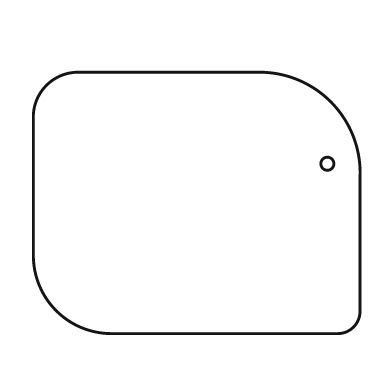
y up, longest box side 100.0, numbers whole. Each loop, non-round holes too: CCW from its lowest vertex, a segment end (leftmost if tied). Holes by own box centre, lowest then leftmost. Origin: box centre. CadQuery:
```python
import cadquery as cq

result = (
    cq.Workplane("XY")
    .moveTo(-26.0, -40.0)
    .lineTo(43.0, -40.0)
    .threePointArc((48.0, -38.0), (50.0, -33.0))
    .lineTo(50.0, 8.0)
    .threePointArc((41.0, 31.0), (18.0, 40.0))
    .lineTo(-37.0, 40.0)
    .threePointArc((-46.0, 36.0), (-50.0, 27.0))
    .lineTo(-50.0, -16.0)
    .threePointArc((-43.0, -33.0), (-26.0, -40.0))
    .close()
    .moveTo(40.0, 12.0)
    .circle(2.0)
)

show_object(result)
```